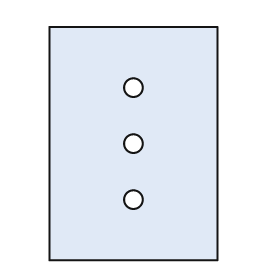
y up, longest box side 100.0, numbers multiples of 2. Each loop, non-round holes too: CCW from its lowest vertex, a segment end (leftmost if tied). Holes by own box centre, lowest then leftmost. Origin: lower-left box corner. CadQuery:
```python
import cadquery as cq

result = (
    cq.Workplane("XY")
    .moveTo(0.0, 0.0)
    .lineTo(72.0, 0.0)
    .lineTo(72.0, 100.0)
    .lineTo(0.0, 100.0)
    .close()
    .moveTo(36.0, 26.0)
    .circle(4.0)
    .moveTo(36.0, 50.0)
    .circle(4.0)
    .moveTo(36.0, 74.0)
    .circle(4.0)
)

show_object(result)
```